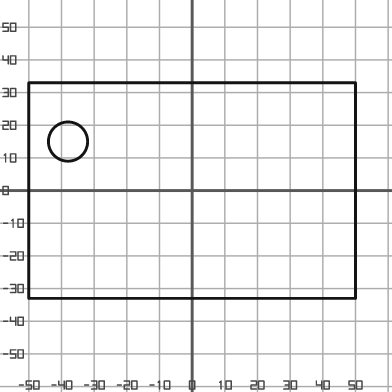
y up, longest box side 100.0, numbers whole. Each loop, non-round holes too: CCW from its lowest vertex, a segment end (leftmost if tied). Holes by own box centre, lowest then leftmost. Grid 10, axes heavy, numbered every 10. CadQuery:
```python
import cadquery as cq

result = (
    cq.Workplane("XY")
    .moveTo(-50.0, -33.0)
    .lineTo(50.0, -33.0)
    .lineTo(50.0, 33.0)
    .lineTo(-50.0, 33.0)
    .close()
    .moveTo(-38.0, 15.0)
    .circle(6.0)
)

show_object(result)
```